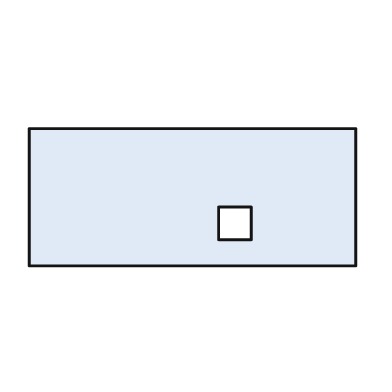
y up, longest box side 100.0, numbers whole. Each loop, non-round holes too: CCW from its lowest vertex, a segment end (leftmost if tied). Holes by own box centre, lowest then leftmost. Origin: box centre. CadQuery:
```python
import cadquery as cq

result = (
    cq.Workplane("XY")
    .moveTo(-50.0, -21.0)
    .lineTo(50.0, -21.0)
    .lineTo(50.0, 21.0)
    .lineTo(-50.0, 21.0)
    .close()
    .moveTo(8.0, -13.0)
    .lineTo(18.0, -13.0)
    .lineTo(18.0, -3.0)
    .lineTo(8.0, -3.0)
    .close()
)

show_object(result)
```